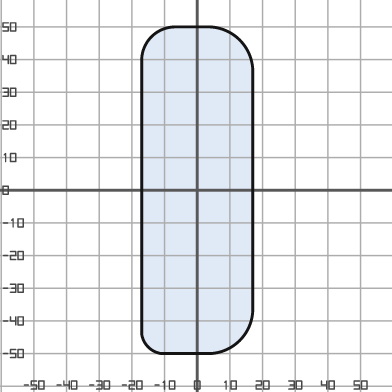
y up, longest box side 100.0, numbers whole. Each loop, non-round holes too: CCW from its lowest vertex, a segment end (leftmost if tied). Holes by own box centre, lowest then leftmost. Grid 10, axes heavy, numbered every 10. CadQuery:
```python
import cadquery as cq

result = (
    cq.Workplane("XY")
    .moveTo(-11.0, -50.0)
    .lineTo(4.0, -50.0)
    .threePointArc((13.0, -46.0), (17.0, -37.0))
    .lineTo(17.0, 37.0)
    .threePointArc((13.0, 46.0), (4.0, 50.0))
    .lineTo(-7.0, 50.0)
    .threePointArc((-14.0, 47.0), (-17.0, 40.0))
    .lineTo(-17.0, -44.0)
    .threePointArc((-15.0, -48.0), (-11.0, -50.0))
    .close()
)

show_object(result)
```